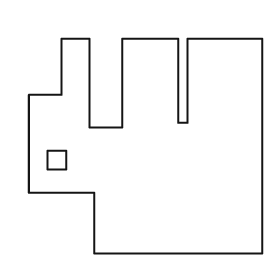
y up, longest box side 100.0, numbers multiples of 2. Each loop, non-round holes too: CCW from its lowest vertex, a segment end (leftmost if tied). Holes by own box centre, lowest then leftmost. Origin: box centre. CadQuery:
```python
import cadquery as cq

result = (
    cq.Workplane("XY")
    .moveTo(-22.0, -46.0)
    .lineTo(50.0, -46.0)
    .lineTo(50.0, 46.0)
    .lineTo(18.0, 46.0)
    .lineTo(18.0, 10.0)
    .lineTo(14.0, 10.0)
    .lineTo(14.0, 46.0)
    .lineTo(-10.0, 46.0)
    .lineTo(-10.0, 8.0)
    .lineTo(-24.0, 8.0)
    .lineTo(-24.0, 46.0)
    .lineTo(-36.0, 46.0)
    .lineTo(-36.0, 22.0)
    .lineTo(-50.0, 22.0)
    .lineTo(-50.0, -20.0)
    .lineTo(-22.0, -20.0)
    .close()
    .moveTo(-42.0, -10.0)
    .lineTo(-34.0, -10.0)
    .lineTo(-34.0, -2.0)
    .lineTo(-42.0, -2.0)
    .close()
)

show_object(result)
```